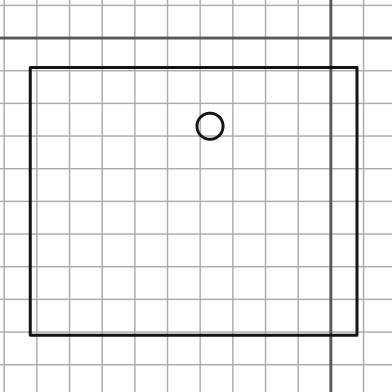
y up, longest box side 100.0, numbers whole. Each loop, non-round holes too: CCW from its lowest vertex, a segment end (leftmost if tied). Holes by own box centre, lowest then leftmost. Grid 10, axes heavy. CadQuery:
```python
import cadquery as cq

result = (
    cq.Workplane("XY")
    .moveTo(-92.0, -91.0)
    .lineTo(8.0, -91.0)
    .lineTo(8.0, -9.0)
    .lineTo(-92.0, -9.0)
    .close()
    .moveTo(-37.0, -27.0)
    .circle(4.0)
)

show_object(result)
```